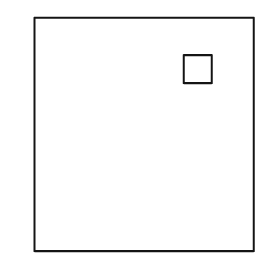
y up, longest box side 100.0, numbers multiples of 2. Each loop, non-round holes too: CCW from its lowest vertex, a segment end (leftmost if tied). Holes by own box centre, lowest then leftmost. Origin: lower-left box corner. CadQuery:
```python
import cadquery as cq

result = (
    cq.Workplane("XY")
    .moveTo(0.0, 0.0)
    .lineTo(94.0, 0.0)
    .lineTo(94.0, 100.0)
    .lineTo(0.0, 100.0)
    .close()
    .moveTo(64.0, 72.0)
    .lineTo(76.0, 72.0)
    .lineTo(76.0, 84.0)
    .lineTo(64.0, 84.0)
    .close()
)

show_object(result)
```